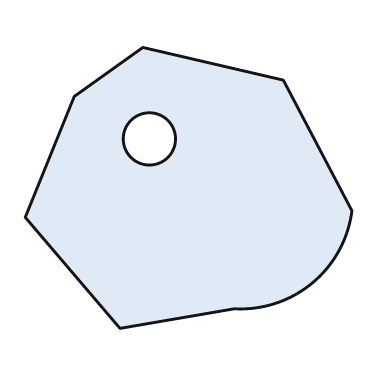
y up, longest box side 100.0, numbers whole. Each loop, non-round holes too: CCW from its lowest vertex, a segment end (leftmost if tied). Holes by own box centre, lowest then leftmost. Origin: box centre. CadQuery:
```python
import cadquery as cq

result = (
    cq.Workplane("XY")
    .moveTo(-21.0, -43.0)
    .lineTo(14.0, -37.0)
    .threePointArc((38.0, -29.0), (50.0, -7.0))
    .lineTo(29.0, 33.0)
    .lineTo(-14.0, 43.0)
    .lineTo(-35.0, 28.0)
    .lineTo(-50.0, -9.0)
    .close()
    .moveTo(-12.0, 15.0)
    .circle(8.0)
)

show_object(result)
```